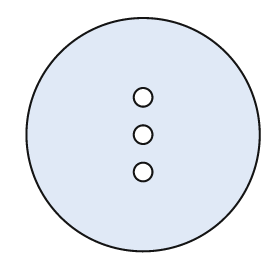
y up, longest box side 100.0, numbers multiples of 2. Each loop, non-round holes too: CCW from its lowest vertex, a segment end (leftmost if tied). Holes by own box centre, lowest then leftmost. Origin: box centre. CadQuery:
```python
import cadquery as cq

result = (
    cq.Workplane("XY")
    .moveTo(0.0, 0.0)
    .circle(50.0)
    .moveTo(0.0, -16.0)
    .circle(4.0)
    .moveTo(0.0, 0.0)
    .circle(4.0)
    .moveTo(0.0, 16.0)
    .circle(4.0)
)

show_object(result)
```